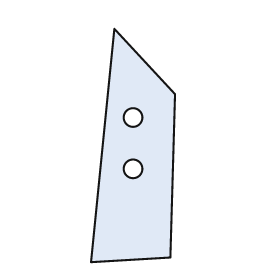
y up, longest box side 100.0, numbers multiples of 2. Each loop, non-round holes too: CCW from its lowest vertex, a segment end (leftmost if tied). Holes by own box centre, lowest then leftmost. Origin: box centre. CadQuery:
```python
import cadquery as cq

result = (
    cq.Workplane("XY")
    .moveTo(-18.0, -50.0)
    .lineTo(16.0, -48.0)
    .lineTo(18.0, 22.0)
    .lineTo(-8.0, 50.0)
    .close()
    .moveTo(0.0, -10.0)
    .circle(4.0)
    .moveTo(0.0, 12.0)
    .circle(4.0)
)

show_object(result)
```